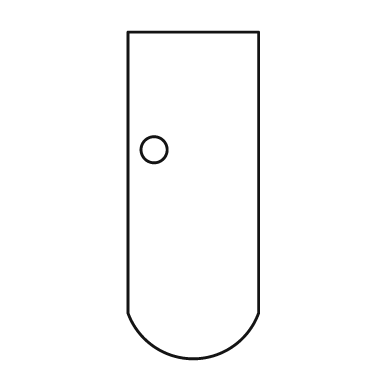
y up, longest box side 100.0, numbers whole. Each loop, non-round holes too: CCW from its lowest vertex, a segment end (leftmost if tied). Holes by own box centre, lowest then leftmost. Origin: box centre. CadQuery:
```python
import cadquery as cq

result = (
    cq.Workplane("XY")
    .moveTo(-20.0, -36.0)
    .threePointArc((0.0, -50.0), (20.0, -36.0))
    .lineTo(20.0, 50.0)
    .lineTo(-20.0, 50.0)
    .close()
    .moveTo(-12.0, 14.0)
    .circle(4.0)
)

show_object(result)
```